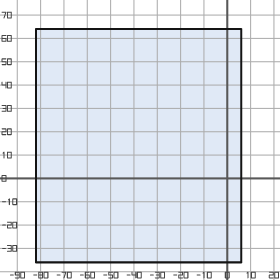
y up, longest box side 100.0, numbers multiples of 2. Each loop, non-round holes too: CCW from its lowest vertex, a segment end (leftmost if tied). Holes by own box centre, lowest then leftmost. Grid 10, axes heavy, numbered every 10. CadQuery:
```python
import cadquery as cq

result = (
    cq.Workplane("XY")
    .moveTo(-82.0, -36.0)
    .lineTo(6.0, -36.0)
    .lineTo(6.0, 64.0)
    .lineTo(-82.0, 64.0)
    .close()
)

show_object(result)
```